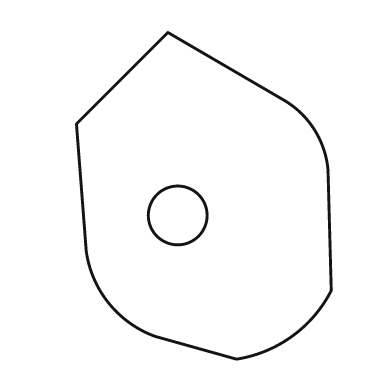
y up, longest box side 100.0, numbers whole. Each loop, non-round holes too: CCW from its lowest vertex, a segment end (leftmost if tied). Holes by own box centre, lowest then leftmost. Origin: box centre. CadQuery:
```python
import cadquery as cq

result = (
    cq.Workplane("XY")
    .moveTo(10.0, -50.0)
    .threePointArc((27.0, -43.0), (39.0, -29.0))
    .lineTo(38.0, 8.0)
    .threePointArc((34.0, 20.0), (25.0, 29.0))
    .lineTo(-11.0, 50.0)
    .lineTo(-39.0, 22.0)
    .lineTo(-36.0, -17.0)
    .threePointArc((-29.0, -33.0), (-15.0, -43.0))
    .close()
    .moveTo(-8.0, -6.0)
    .circle(9.0)
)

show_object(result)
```